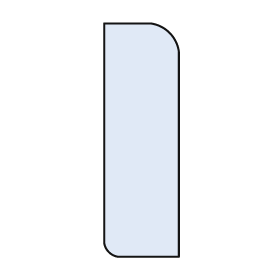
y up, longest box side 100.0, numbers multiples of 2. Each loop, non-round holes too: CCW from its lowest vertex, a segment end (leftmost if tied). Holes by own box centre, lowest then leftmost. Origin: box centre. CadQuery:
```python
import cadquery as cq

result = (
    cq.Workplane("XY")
    .moveTo(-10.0, -50.0)
    .lineTo(16.0, -50.0)
    .lineTo(16.0, 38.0)
    .threePointArc((12.0, 46.0), (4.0, 50.0))
    .lineTo(-16.0, 50.0)
    .lineTo(-16.0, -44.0)
    .threePointArc((-14.0, -48.0), (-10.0, -50.0))
    .close()
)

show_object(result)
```